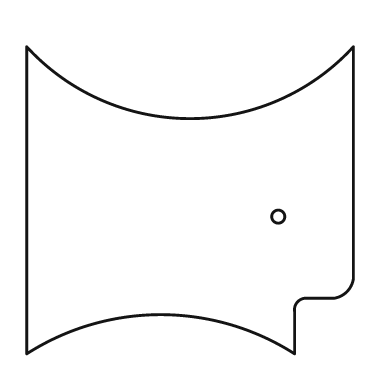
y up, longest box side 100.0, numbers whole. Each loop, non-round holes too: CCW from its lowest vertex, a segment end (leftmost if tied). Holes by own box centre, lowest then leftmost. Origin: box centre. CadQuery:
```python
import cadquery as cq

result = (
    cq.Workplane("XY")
    .moveTo(-50.0, -47.0)
    .threePointArc((-9.0, -35.0), (32.0, -47.0))
    .lineTo(32.0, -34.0)
    .threePointArc((33.0, -31.0), (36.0, -30.0))
    .lineTo(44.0, -30.0)
    .threePointArc((48.0, -28.0), (50.0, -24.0))
    .lineTo(50.0, 47.0)
    .threePointArc((0.0, 25.0), (-50.0, 47.0))
    .close()
    .moveTo(27.0, -5.0)
    .circle(2.0)
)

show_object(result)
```